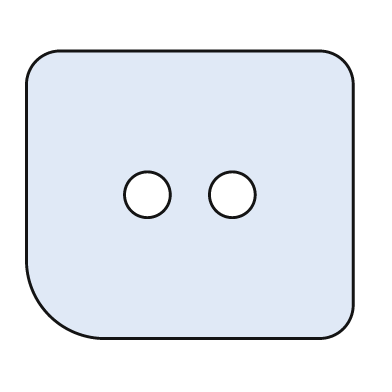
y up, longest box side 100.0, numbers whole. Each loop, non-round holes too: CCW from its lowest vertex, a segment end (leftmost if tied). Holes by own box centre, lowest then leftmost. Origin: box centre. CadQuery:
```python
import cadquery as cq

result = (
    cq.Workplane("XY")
    .moveTo(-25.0, -44.0)
    .lineTo(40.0, -44.0)
    .threePointArc((47.0, -41.0), (50.0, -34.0))
    .lineTo(50.0, 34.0)
    .threePointArc((47.0, 41.0), (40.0, 44.0))
    .lineTo(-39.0, 44.0)
    .threePointArc((-47.0, 41.0), (-50.0, 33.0))
    .lineTo(-50.0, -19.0)
    .threePointArc((-43.0, -37.0), (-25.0, -44.0))
    .close()
    .moveTo(-13.0, 0.0)
    .circle(7.0)
    .moveTo(13.0, 0.0)
    .circle(7.0)
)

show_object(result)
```